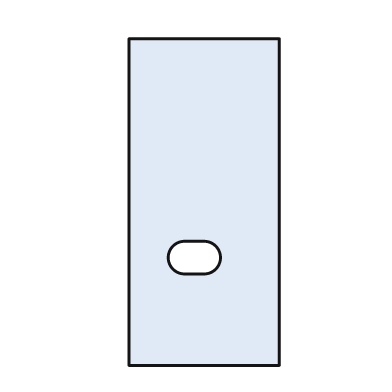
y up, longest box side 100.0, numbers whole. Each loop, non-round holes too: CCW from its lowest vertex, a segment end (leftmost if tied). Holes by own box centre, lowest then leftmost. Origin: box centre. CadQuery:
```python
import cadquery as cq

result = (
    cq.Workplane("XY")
    .moveTo(-23.0, -50.0)
    .lineTo(23.0, -50.0)
    .lineTo(23.0, 50.0)
    .lineTo(-23.0, 50.0)
    .close()
    .moveTo(-6.0, -22.0)
    .lineTo(0.0, -22.0)
    .threePointArc((5.0, -17.0), (0.0, -12.0))
    .lineTo(-6.0, -12.0)
    .threePointArc((-11.0, -17.0), (-6.0, -22.0))
    .close()
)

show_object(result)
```